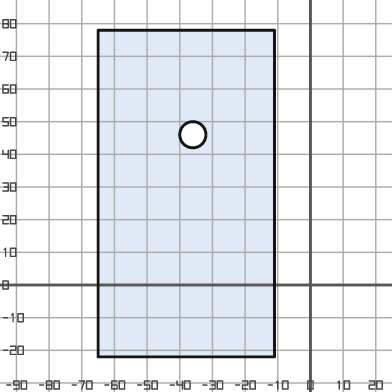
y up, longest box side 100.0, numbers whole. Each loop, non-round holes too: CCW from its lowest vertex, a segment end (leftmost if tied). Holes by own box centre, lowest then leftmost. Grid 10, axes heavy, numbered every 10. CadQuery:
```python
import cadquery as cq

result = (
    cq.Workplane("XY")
    .moveTo(-65.0, -22.0)
    .lineTo(-11.0, -22.0)
    .lineTo(-11.0, 78.0)
    .lineTo(-65.0, 78.0)
    .close()
    .moveTo(-36.0, 46.0)
    .circle(4.0)
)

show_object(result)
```